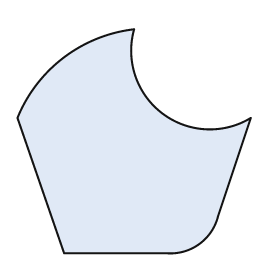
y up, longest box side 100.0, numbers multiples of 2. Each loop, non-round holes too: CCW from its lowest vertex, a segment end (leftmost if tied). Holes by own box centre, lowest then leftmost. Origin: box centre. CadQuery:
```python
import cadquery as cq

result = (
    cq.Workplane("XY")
    .moveTo(-30.0, -48.0)
    .lineTo(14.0, -48.0)
    .threePointArc((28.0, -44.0), (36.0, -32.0))
    .lineTo(50.0, 10.0)
    .threePointArc((12.0, 12.0), (0.0, 48.0))
    .threePointArc((-30.0, 36.0), (-50.0, 10.0))
    .close()
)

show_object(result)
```